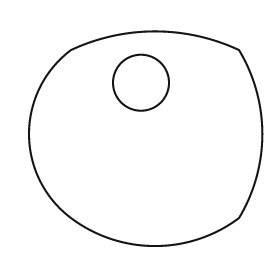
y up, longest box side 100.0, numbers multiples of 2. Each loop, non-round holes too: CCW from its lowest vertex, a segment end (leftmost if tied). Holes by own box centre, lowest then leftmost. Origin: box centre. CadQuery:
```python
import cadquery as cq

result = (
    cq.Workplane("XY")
    .moveTo(-32.0, -34.0)
    .threePointArc((4.0, -46.0), (40.0, -34.0))
    .threePointArc((50.0, 2.0), (40.0, 38.0))
    .threePointArc((4.0, 46.0), (-32.0, 38.0))
    .threePointArc((-50.0, 2.0), (-32.0, -34.0))
    .close()
    .moveTo(-2.0, 24.0)
    .circle(12.0)
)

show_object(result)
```